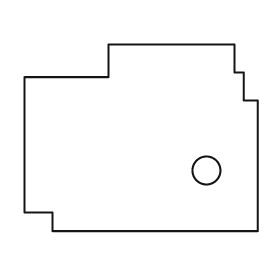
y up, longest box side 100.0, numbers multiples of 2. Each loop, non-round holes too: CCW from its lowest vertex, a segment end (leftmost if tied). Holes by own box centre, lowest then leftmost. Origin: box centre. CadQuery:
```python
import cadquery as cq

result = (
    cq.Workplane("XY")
    .moveTo(-38.0, -40.0)
    .lineTo(50.0, -40.0)
    .lineTo(50.0, 16.0)
    .lineTo(44.0, 16.0)
    .lineTo(44.0, 28.0)
    .lineTo(40.0, 28.0)
    .lineTo(40.0, 40.0)
    .lineTo(-14.0, 40.0)
    .lineTo(-14.0, 26.0)
    .lineTo(-50.0, 26.0)
    .lineTo(-50.0, -32.0)
    .lineTo(-38.0, -32.0)
    .close()
    .moveTo(28.0, -14.0)
    .circle(6.0)
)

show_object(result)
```